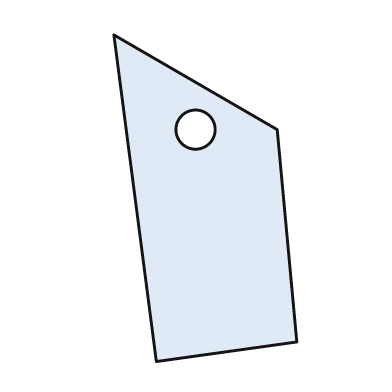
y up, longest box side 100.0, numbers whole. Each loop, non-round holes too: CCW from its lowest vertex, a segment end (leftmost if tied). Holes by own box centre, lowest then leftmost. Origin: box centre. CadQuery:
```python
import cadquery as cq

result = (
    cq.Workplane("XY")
    .moveTo(-15.0, -50.0)
    .lineTo(28.0, -44.0)
    .lineTo(22.0, 21.0)
    .lineTo(-28.0, 50.0)
    .close()
    .moveTo(-3.0, 21.0)
    .circle(6.0)
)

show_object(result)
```